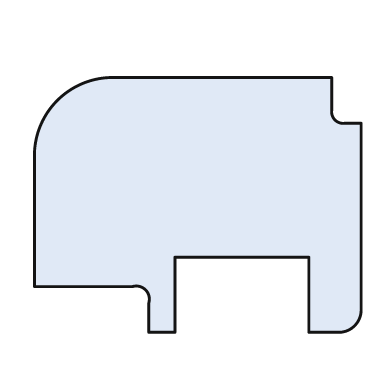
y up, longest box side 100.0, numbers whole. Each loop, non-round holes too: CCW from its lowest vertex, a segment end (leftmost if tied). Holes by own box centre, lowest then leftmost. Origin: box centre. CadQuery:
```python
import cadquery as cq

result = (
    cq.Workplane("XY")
    .moveTo(-15.0, -39.0)
    .lineTo(-7.0, -39.0)
    .lineTo(-7.0, -16.0)
    .lineTo(34.0, -16.0)
    .lineTo(34.0, -39.0)
    .lineTo(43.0, -39.0)
    .threePointArc((48.0, -37.0), (50.0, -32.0))
    .lineTo(50.0, 25.0)
    .lineTo(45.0, 25.0)
    .threePointArc((42.0, 26.0), (41.0, 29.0))
    .lineTo(41.0, 39.0)
    .lineTo(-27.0, 39.0)
    .threePointArc((-43.0, 32.0), (-50.0, 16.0))
    .lineTo(-50.0, -25.0)
    .lineTo(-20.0, -25.0)
    .threePointArc((-16.0, -26.0), (-15.0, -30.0))
    .close()
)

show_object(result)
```